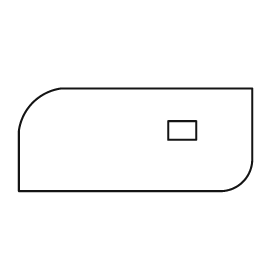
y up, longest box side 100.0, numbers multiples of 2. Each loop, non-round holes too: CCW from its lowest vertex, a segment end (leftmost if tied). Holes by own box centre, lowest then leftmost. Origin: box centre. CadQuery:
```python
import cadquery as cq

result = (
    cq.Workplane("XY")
    .moveTo(-50.0, -22.0)
    .lineTo(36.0, -22.0)
    .threePointArc((46.0, -18.0), (50.0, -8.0))
    .lineTo(50.0, 22.0)
    .lineTo(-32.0, 22.0)
    .threePointArc((-44.0, 16.0), (-50.0, 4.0))
    .close()
    .moveTo(14.0, 0.0)
    .lineTo(26.0, 0.0)
    .lineTo(26.0, 8.0)
    .lineTo(14.0, 8.0)
    .close()
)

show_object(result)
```